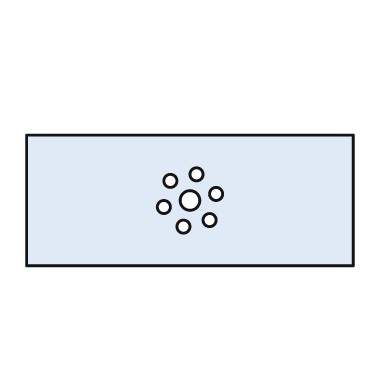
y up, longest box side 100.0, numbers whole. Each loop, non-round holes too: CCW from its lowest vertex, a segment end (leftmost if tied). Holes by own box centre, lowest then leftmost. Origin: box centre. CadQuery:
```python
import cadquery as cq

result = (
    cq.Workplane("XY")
    .moveTo(-50.0, -20.0)
    .lineTo(50.0, -20.0)
    .lineTo(50.0, 20.0)
    .lineTo(-50.0, 20.0)
    .close()
    .moveTo(-2.0, -8.0)
    .circle(2.0)
    .moveTo(6.0, -6.0)
    .circle(2.0)
    .moveTo(-8.0, -2.0)
    .circle(2.0)
    .moveTo(0.0, 0.0)
    .circle(3.0)
    .moveTo(8.0, 2.0)
    .circle(2.0)
    .moveTo(-6.0, 6.0)
    .circle(2.0)
    .moveTo(2.0, 8.0)
    .circle(2.0)
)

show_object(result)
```